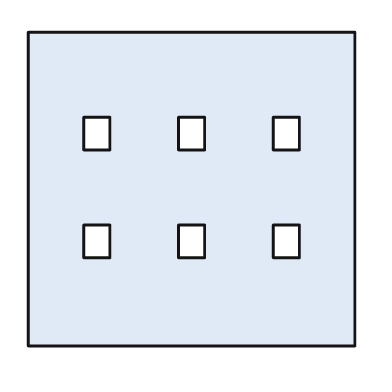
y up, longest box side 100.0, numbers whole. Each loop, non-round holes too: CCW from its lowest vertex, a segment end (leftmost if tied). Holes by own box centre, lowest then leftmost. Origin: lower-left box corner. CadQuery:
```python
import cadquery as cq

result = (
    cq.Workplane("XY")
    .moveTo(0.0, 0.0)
    .lineTo(100.0, 0.0)
    .lineTo(100.0, 96.0)
    .lineTo(0.0, 96.0)
    .close()
    .moveTo(17.0, 27.0)
    .lineTo(25.0, 27.0)
    .lineTo(25.0, 37.0)
    .lineTo(17.0, 37.0)
    .close()
    .moveTo(46.0, 27.0)
    .lineTo(54.0, 27.0)
    .lineTo(54.0, 37.0)
    .lineTo(46.0, 37.0)
    .close()
    .moveTo(75.0, 27.0)
    .lineTo(83.0, 27.0)
    .lineTo(83.0, 37.0)
    .lineTo(75.0, 37.0)
    .close()
    .moveTo(17.0, 60.0)
    .lineTo(25.0, 60.0)
    .lineTo(25.0, 70.0)
    .lineTo(17.0, 70.0)
    .close()
    .moveTo(46.0, 60.0)
    .lineTo(54.0, 60.0)
    .lineTo(54.0, 70.0)
    .lineTo(46.0, 70.0)
    .close()
    .moveTo(75.0, 60.0)
    .lineTo(83.0, 60.0)
    .lineTo(83.0, 70.0)
    .lineTo(75.0, 70.0)
    .close()
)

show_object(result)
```